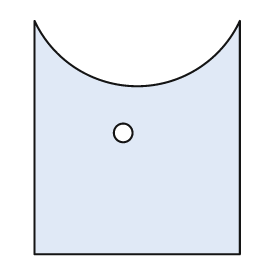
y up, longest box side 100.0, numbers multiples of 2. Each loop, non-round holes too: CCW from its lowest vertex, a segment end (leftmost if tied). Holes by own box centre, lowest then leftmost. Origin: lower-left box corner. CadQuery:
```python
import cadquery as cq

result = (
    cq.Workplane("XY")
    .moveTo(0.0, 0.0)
    .lineTo(88.0, 0.0)
    .lineTo(88.0, 100.0)
    .threePointArc((44.0, 72.0), (0.0, 100.0))
    .close()
    .moveTo(38.0, 52.0)
    .circle(4.0)
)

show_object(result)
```